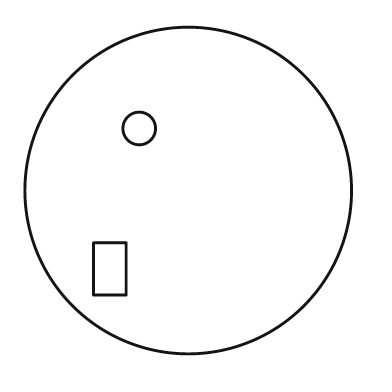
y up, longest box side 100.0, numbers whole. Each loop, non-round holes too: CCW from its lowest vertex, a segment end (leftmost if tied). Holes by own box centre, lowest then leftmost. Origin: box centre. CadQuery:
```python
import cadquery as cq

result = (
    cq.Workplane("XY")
    .moveTo(0.0, 0.0)
    .circle(50.0)
    .moveTo(-29.0, -32.0)
    .lineTo(-19.0, -32.0)
    .lineTo(-19.0, -16.0)
    .lineTo(-29.0, -16.0)
    .close()
    .moveTo(-15.0, 19.0)
    .circle(5.0)
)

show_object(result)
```